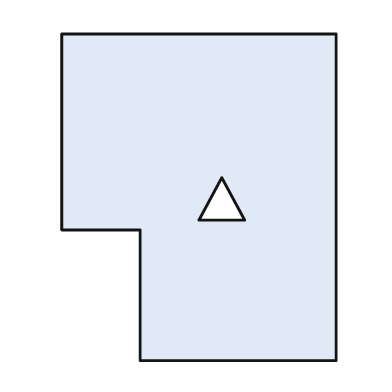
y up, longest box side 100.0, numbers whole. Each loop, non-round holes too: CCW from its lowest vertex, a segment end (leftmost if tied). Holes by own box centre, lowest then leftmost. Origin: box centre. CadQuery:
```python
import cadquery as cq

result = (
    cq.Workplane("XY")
    .moveTo(-18.0, -50.0)
    .lineTo(42.0, -50.0)
    .lineTo(42.0, 50.0)
    .lineTo(-42.0, 50.0)
    .lineTo(-42.0, -10.0)
    .lineTo(-18.0, -10.0)
    .close()
    .moveTo(0.0, -7.0)
    .lineTo(14.0, -7.0)
    .lineTo(7.0, 6.0)
    .close()
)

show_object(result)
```